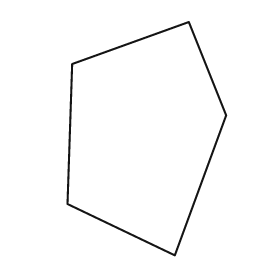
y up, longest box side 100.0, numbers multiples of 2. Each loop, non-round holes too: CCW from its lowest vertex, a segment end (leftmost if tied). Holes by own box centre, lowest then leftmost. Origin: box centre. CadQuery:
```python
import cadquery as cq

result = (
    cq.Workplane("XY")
    .moveTo(12.0, -50.0)
    .lineTo(34.0, 10.0)
    .lineTo(18.0, 50.0)
    .lineTo(-32.0, 32.0)
    .lineTo(-34.0, -28.0)
    .close()
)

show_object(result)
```